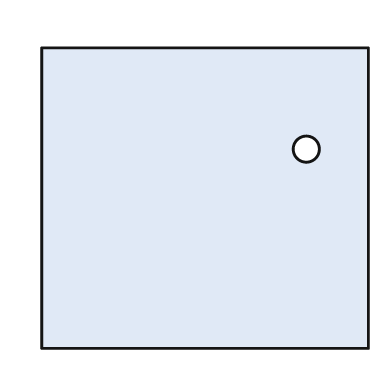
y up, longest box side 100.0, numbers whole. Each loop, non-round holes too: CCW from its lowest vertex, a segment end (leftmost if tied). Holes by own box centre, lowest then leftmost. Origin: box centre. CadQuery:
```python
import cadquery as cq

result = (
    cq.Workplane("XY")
    .moveTo(-50.0, -46.0)
    .lineTo(50.0, -46.0)
    .lineTo(50.0, 46.0)
    .lineTo(-50.0, 46.0)
    .close()
    .moveTo(31.0, 15.0)
    .circle(4.0)
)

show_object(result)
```